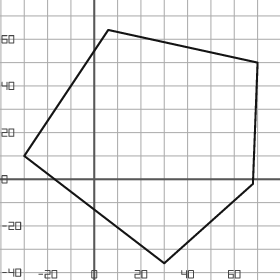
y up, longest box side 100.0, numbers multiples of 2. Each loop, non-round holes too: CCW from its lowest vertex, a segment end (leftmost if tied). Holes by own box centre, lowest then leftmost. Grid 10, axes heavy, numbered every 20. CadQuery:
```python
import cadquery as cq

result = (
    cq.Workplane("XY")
    .moveTo(30.0, -36.0)
    .lineTo(68.0, -2.0)
    .lineTo(70.0, 50.0)
    .lineTo(6.0, 64.0)
    .lineTo(-30.0, 10.0)
    .close()
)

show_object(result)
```